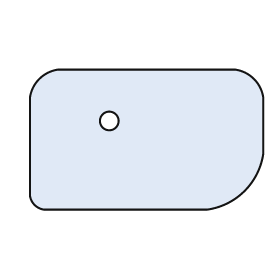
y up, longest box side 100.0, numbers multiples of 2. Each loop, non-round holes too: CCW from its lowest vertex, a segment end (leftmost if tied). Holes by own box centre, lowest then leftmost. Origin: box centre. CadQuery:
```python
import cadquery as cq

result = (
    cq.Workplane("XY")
    .moveTo(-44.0, -30.0)
    .lineTo(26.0, -30.0)
    .threePointArc((42.0, -22.0), (50.0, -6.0))
    .lineTo(50.0, 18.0)
    .threePointArc((46.0, 26.0), (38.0, 30.0))
    .lineTo(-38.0, 30.0)
    .threePointArc((-46.0, 26.0), (-50.0, 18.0))
    .lineTo(-50.0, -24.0)
    .threePointArc((-48.0, -28.0), (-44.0, -30.0))
    .close()
    .moveTo(-16.0, 8.0)
    .circle(4.0)
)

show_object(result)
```